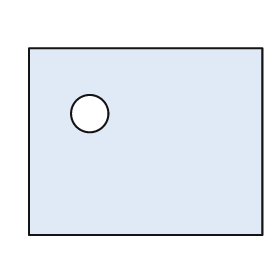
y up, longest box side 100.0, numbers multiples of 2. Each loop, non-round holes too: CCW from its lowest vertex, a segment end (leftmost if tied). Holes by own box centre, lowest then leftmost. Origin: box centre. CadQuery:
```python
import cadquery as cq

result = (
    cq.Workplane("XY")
    .moveTo(-50.0, -40.0)
    .lineTo(50.0, -40.0)
    .lineTo(50.0, 40.0)
    .lineTo(-50.0, 40.0)
    .close()
    .moveTo(-24.0, 12.0)
    .circle(8.0)
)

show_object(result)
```